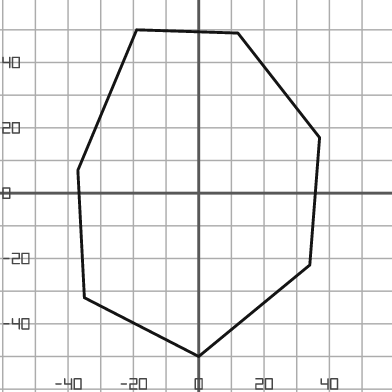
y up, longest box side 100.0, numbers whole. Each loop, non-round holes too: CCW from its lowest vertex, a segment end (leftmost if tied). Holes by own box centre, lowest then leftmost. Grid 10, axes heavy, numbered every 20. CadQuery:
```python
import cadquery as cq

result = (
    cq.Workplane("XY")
    .moveTo(0.0, -50.0)
    .lineTo(34.0, -22.0)
    .lineTo(37.0, 17.0)
    .lineTo(12.0, 49.0)
    .lineTo(-19.0, 50.0)
    .lineTo(-37.0, 7.0)
    .lineTo(-35.0, -32.0)
    .close()
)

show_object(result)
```